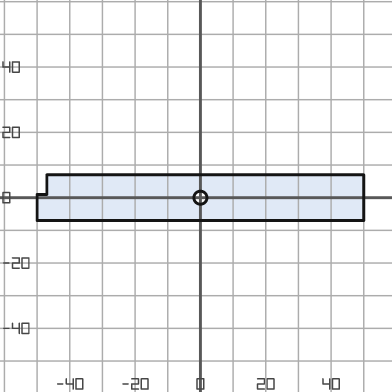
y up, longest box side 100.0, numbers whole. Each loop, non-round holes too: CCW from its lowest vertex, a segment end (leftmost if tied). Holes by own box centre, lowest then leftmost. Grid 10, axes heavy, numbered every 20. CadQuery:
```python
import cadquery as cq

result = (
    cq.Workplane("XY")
    .moveTo(-50.0, -7.0)
    .lineTo(50.0, -7.0)
    .lineTo(50.0, 7.0)
    .lineTo(-47.0, 7.0)
    .lineTo(-47.0, 1.0)
    .lineTo(-50.0, 1.0)
    .close()
    .moveTo(0.0, 0.0)
    .circle(2.0)
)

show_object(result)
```